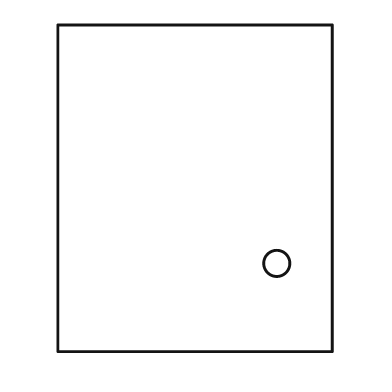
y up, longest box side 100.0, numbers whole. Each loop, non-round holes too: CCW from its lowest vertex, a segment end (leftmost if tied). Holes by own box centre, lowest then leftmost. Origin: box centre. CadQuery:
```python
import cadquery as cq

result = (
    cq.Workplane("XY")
    .moveTo(-42.0, -50.0)
    .lineTo(42.0, -50.0)
    .lineTo(42.0, 50.0)
    .lineTo(-42.0, 50.0)
    .close()
    .moveTo(25.0, -23.0)
    .circle(4.0)
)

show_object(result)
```